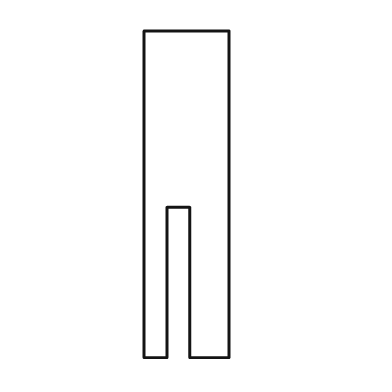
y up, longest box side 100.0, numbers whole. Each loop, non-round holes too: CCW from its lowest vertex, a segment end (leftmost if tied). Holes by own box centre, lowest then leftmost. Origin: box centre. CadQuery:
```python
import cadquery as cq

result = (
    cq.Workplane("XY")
    .moveTo(-13.0, -50.0)
    .lineTo(-6.0, -50.0)
    .lineTo(-6.0, -4.0)
    .lineTo(1.0, -4.0)
    .lineTo(1.0, -50.0)
    .lineTo(13.0, -50.0)
    .lineTo(13.0, 50.0)
    .lineTo(-13.0, 50.0)
    .close()
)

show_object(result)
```